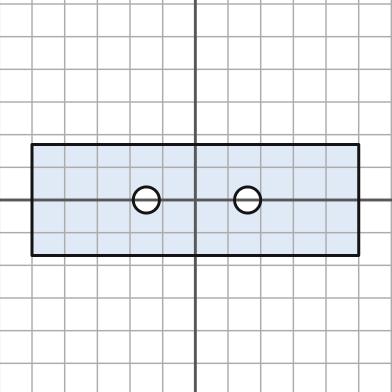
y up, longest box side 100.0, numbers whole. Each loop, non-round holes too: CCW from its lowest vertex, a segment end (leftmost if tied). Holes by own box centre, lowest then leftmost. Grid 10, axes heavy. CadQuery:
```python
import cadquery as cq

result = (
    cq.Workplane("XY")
    .moveTo(-50.0, -17.0)
    .lineTo(50.0, -17.0)
    .lineTo(50.0, 17.0)
    .lineTo(-50.0, 17.0)
    .close()
    .moveTo(-15.0, 0.0)
    .circle(4.0)
    .moveTo(16.0, 0.0)
    .circle(4.0)
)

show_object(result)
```